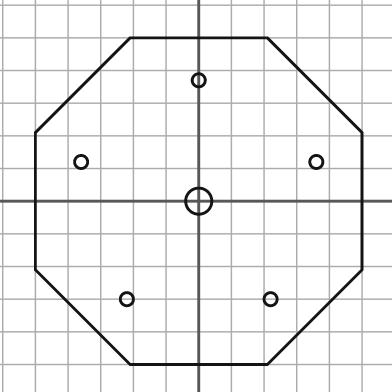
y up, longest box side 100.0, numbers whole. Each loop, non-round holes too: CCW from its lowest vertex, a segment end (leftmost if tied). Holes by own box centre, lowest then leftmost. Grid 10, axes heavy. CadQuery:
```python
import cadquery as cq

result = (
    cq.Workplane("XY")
    .moveTo(-21.0, -50.0)
    .lineTo(21.0, -50.0)
    .lineTo(50.0, -21.0)
    .lineTo(50.0, 21.0)
    .lineTo(21.0, 50.0)
    .lineTo(-21.0, 50.0)
    .lineTo(-50.0, 21.0)
    .lineTo(-50.0, -21.0)
    .close()
    .moveTo(-22.0, -30.0)
    .circle(2.0)
    .moveTo(22.0, -30.0)
    .circle(2.0)
    .moveTo(0.0, 0.0)
    .circle(4.0)
    .moveTo(-36.0, 12.0)
    .circle(2.0)
    .moveTo(36.0, 12.0)
    .circle(2.0)
    .moveTo(0.0, 37.0)
    .circle(2.0)
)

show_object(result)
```